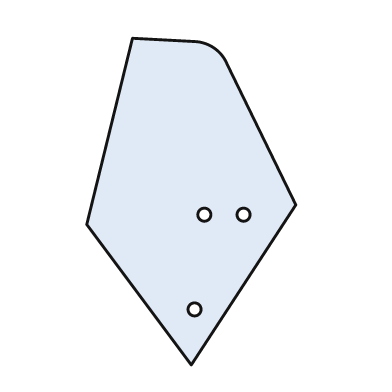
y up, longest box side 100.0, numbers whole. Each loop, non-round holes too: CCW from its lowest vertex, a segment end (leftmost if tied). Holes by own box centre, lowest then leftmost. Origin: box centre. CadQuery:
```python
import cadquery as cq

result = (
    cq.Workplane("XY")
    .moveTo(0.0, -50.0)
    .lineTo(32.0, -1.0)
    .lineTo(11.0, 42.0)
    .threePointArc((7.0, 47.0), (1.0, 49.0))
    .lineTo(-18.0, 50.0)
    .lineTo(-32.0, -7.0)
    .close()
    .moveTo(1.0, -33.0)
    .circle(2.0)
    .moveTo(4.0, -4.0)
    .circle(2.0)
    .moveTo(16.0, -4.0)
    .circle(2.0)
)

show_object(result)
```